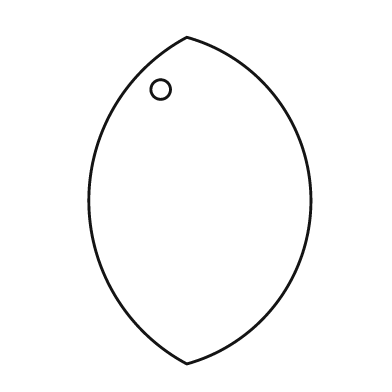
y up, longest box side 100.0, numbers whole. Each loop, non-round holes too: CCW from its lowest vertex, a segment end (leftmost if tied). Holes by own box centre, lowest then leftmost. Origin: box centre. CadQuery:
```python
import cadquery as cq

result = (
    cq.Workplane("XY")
    .moveTo(-4.0, -50.0)
    .threePointArc((34.0, 0.0), (-4.0, 50.0))
    .threePointArc((-34.0, 0.0), (-4.0, -50.0))
    .close()
    .moveTo(-12.0, 34.0)
    .circle(3.0)
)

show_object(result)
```